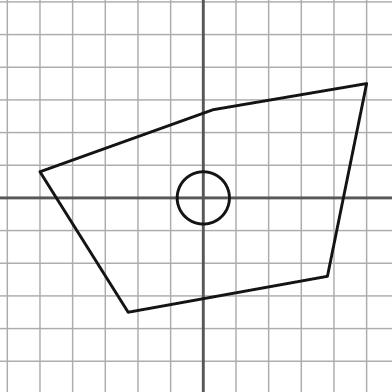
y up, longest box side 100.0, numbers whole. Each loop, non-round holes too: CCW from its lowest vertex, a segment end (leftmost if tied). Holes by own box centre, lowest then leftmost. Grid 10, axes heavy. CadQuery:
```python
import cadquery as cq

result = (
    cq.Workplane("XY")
    .moveTo(-23.0, -35.0)
    .lineTo(38.0, -24.0)
    .lineTo(50.0, 35.0)
    .lineTo(3.0, 27.0)
    .lineTo(-50.0, 8.0)
    .close()
    .moveTo(0.0, 0.0)
    .circle(8.0)
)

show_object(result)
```